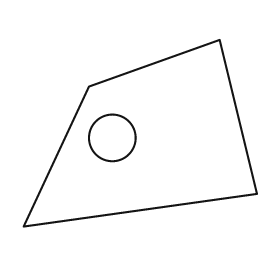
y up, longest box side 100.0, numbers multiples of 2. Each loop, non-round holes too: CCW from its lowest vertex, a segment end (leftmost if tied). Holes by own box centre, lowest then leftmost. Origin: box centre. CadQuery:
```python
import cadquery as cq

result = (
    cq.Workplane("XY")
    .moveTo(-50.0, -40.0)
    .lineTo(50.0, -26.0)
    .lineTo(34.0, 40.0)
    .lineTo(-22.0, 20.0)
    .close()
    .moveTo(-12.0, -2.0)
    .circle(10.0)
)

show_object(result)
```